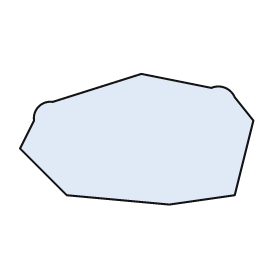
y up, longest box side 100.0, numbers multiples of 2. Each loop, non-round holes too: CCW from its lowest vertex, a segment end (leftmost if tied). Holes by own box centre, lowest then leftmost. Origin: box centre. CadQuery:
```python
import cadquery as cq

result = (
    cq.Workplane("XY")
    .moveTo(14.0, -28.0)
    .lineTo(42.0, -24.0)
    .lineTo(50.0, 8.0)
    .lineTo(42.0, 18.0)
    .threePointArc((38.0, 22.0), (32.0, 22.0))
    .lineTo(2.0, 28.0)
    .lineTo(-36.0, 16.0)
    .threePointArc((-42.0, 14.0), (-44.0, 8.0))
    .lineTo(-50.0, -4.0)
    .lineTo(-30.0, -24.0)
    .close()
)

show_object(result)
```